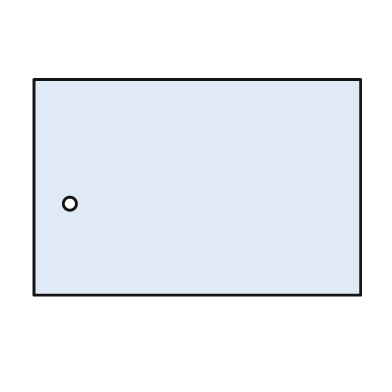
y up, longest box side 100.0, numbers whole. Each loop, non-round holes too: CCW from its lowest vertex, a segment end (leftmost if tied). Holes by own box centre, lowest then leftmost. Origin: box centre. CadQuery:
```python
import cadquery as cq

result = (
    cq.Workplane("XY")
    .moveTo(-50.0, -33.0)
    .lineTo(50.0, -33.0)
    .lineTo(50.0, 33.0)
    .lineTo(-50.0, 33.0)
    .close()
    .moveTo(-39.0, -5.0)
    .circle(2.0)
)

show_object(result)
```